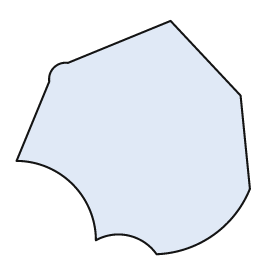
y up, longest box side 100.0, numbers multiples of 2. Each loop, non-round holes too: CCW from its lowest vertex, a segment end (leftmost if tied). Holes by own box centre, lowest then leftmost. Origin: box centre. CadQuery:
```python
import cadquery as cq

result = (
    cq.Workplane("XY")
    .moveTo(10.0, -50.0)
    .threePointArc((34.0, -42.0), (50.0, -22.0))
    .lineTo(46.0, 18.0)
    .lineTo(16.0, 50.0)
    .lineTo(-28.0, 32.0)
    .threePointArc((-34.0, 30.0), (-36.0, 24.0))
    .lineTo(-50.0, -10.0)
    .threePointArc((-26.0, -20.0), (-16.0, -44.0))
    .threePointArc((-2.0, -42.0), (10.0, -50.0))
    .close()
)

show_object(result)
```